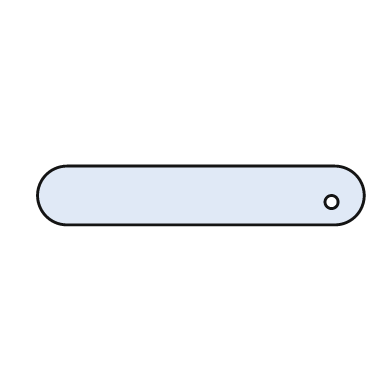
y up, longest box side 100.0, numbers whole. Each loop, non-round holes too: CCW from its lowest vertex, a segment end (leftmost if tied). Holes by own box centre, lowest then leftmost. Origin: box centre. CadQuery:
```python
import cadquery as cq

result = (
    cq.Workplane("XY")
    .moveTo(-41.0, -9.0)
    .lineTo(41.0, -9.0)
    .threePointArc((50.0, 0.0), (41.0, 9.0))
    .lineTo(-41.0, 9.0)
    .threePointArc((-50.0, 0.0), (-41.0, -9.0))
    .close()
    .moveTo(40.0, -2.0)
    .circle(2.0)
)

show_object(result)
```